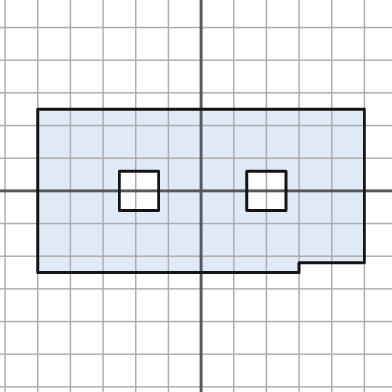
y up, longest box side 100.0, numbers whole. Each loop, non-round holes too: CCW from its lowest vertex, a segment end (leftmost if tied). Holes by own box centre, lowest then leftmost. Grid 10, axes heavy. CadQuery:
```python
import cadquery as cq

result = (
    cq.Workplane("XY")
    .moveTo(-50.0, -25.0)
    .lineTo(30.0, -25.0)
    .lineTo(30.0, -22.0)
    .lineTo(50.0, -22.0)
    .lineTo(50.0, 25.0)
    .lineTo(-50.0, 25.0)
    .close()
    .moveTo(-25.0, -6.0)
    .lineTo(-13.0, -6.0)
    .lineTo(-13.0, 6.0)
    .lineTo(-25.0, 6.0)
    .close()
    .moveTo(14.0, -6.0)
    .lineTo(26.0, -6.0)
    .lineTo(26.0, 6.0)
    .lineTo(14.0, 6.0)
    .close()
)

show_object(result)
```